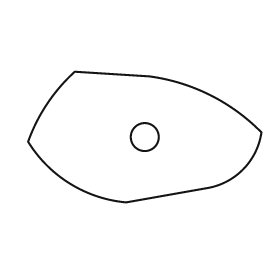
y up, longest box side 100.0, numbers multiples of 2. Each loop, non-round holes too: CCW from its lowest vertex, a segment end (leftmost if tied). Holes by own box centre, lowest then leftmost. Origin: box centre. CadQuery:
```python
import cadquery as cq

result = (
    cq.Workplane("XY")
    .moveTo(-8.0, -28.0)
    .lineTo(26.0, -22.0)
    .threePointArc((42.0, -14.0), (50.0, 2.0))
    .threePointArc((28.0, 18.0), (2.0, 26.0))
    .lineTo(-30.0, 28.0)
    .threePointArc((-42.0, 14.0), (-50.0, -2.0))
    .threePointArc((-32.0, -20.0), (-8.0, -28.0))
    .close()
    .moveTo(0.0, 0.0)
    .circle(6.0)
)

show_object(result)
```